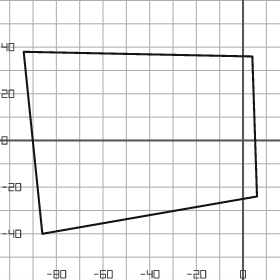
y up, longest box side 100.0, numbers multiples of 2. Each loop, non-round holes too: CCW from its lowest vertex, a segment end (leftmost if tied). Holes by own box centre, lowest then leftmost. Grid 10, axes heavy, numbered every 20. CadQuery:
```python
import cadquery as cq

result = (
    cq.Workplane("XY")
    .moveTo(-86.0, -40.0)
    .lineTo(6.0, -24.0)
    .lineTo(4.0, 36.0)
    .lineTo(-94.0, 38.0)
    .close()
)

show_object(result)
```